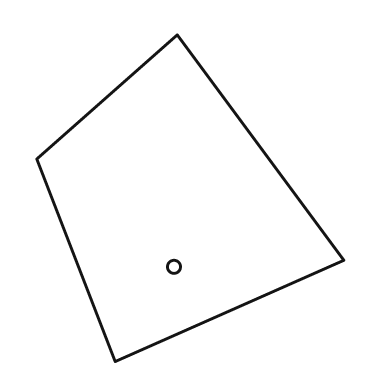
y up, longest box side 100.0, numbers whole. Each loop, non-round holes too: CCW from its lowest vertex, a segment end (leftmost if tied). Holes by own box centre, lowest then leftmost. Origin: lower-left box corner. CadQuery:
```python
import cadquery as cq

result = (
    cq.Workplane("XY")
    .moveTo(24.0, 0.0)
    .lineTo(94.0, 31.0)
    .lineTo(43.0, 100.0)
    .lineTo(0.0, 62.0)
    .close()
    .moveTo(42.0, 29.0)
    .circle(2.0)
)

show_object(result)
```